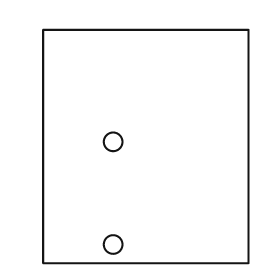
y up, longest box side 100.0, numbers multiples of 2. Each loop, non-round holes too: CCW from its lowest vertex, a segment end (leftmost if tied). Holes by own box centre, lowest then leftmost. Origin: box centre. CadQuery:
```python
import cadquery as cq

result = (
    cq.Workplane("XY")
    .moveTo(-44.0, -50.0)
    .lineTo(44.0, -50.0)
    .lineTo(44.0, 50.0)
    .lineTo(-44.0, 50.0)
    .close()
    .moveTo(-14.0, -42.0)
    .circle(4.0)
    .moveTo(-14.0, 2.0)
    .circle(4.0)
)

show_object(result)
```